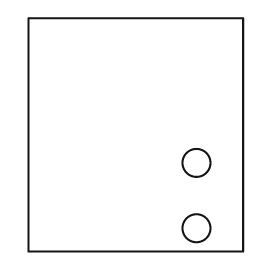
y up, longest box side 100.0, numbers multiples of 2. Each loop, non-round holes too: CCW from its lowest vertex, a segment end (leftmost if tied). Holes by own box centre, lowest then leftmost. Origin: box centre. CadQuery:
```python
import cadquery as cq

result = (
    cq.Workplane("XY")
    .moveTo(-46.0, -50.0)
    .lineTo(46.0, -50.0)
    .lineTo(46.0, 50.0)
    .lineTo(-46.0, 50.0)
    .close()
    .moveTo(26.0, -40.0)
    .circle(6.0)
    .moveTo(26.0, -12.0)
    .circle(6.0)
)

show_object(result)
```